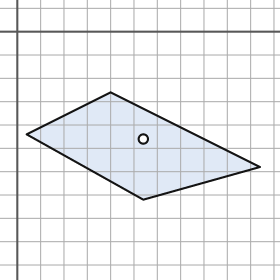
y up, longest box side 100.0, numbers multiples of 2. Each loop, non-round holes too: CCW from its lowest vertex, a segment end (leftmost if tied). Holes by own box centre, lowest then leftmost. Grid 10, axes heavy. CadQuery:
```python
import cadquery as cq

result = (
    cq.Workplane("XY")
    .moveTo(54.0, -72.0)
    .lineTo(104.0, -58.0)
    .lineTo(40.0, -26.0)
    .lineTo(4.0, -44.0)
    .close()
    .moveTo(54.0, -46.0)
    .circle(2.0)
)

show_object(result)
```